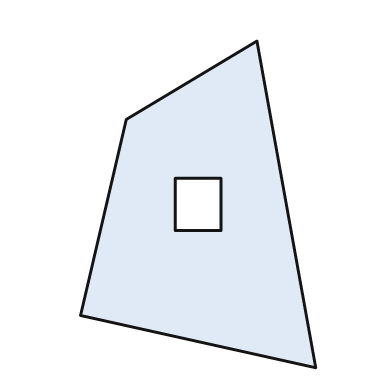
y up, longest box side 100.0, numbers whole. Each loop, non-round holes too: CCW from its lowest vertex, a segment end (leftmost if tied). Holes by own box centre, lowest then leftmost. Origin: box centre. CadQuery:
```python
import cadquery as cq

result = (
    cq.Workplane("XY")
    .moveTo(36.0, -50.0)
    .lineTo(18.0, 50.0)
    .lineTo(-22.0, 26.0)
    .lineTo(-36.0, -34.0)
    .close()
    .moveTo(-7.0, -8.0)
    .lineTo(7.0, -8.0)
    .lineTo(7.0, 8.0)
    .lineTo(-7.0, 8.0)
    .close()
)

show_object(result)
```